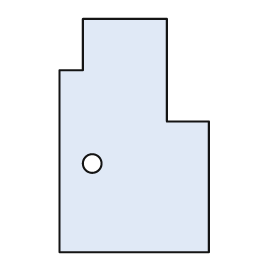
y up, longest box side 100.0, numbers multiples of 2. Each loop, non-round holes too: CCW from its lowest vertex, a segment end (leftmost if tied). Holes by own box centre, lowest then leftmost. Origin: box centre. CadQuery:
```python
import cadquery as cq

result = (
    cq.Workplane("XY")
    .moveTo(-32.0, -50.0)
    .lineTo(32.0, -50.0)
    .lineTo(32.0, 6.0)
    .lineTo(14.0, 6.0)
    .lineTo(14.0, 50.0)
    .lineTo(-22.0, 50.0)
    .lineTo(-22.0, 28.0)
    .lineTo(-32.0, 28.0)
    .close()
    .moveTo(-18.0, -12.0)
    .circle(4.0)
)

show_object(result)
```